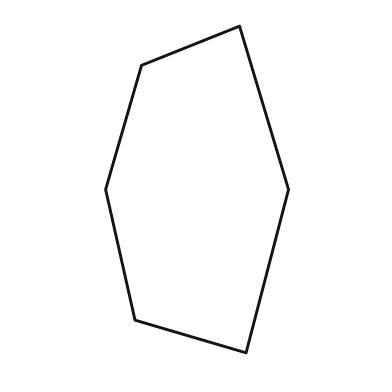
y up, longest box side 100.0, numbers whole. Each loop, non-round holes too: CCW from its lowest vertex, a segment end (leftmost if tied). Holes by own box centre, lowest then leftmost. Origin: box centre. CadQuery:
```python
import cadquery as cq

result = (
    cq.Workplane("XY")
    .moveTo(15.0, -50.0)
    .lineTo(28.0, 0.0)
    .lineTo(13.0, 50.0)
    .lineTo(-17.0, 38.0)
    .lineTo(-28.0, 0.0)
    .lineTo(-19.0, -40.0)
    .close()
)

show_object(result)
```